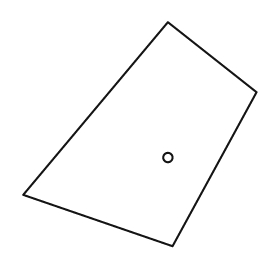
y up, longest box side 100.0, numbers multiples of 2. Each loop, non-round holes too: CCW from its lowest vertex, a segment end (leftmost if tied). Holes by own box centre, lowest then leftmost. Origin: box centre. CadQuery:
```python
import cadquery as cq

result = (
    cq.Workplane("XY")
    .moveTo(14.0, -48.0)
    .lineTo(50.0, 18.0)
    .lineTo(12.0, 48.0)
    .lineTo(-50.0, -26.0)
    .close()
    .moveTo(12.0, -10.0)
    .circle(2.0)
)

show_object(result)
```